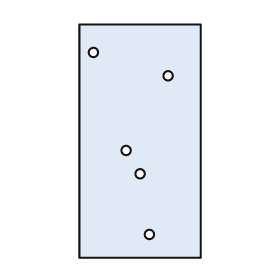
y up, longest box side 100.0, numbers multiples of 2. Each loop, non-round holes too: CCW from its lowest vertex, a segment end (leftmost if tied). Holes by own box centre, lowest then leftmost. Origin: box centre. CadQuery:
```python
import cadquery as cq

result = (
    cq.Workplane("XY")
    .moveTo(-26.0, -50.0)
    .lineTo(26.0, -50.0)
    .lineTo(26.0, 50.0)
    .lineTo(-26.0, 50.0)
    .close()
    .moveTo(4.0, -40.0)
    .circle(2.0)
    .moveTo(0.0, -14.0)
    .circle(2.0)
    .moveTo(-6.0, -4.0)
    .circle(2.0)
    .moveTo(12.0, 28.0)
    .circle(2.0)
    .moveTo(-20.0, 38.0)
    .circle(2.0)
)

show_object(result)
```